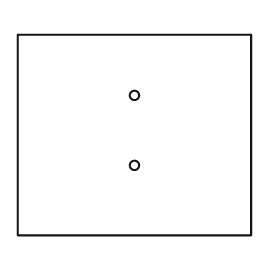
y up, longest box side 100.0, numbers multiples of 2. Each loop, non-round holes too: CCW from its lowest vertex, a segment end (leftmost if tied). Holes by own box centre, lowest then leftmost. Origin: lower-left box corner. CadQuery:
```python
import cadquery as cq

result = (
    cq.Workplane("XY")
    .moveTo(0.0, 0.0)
    .lineTo(100.0, 0.0)
    .lineTo(100.0, 86.0)
    .lineTo(0.0, 86.0)
    .close()
    .moveTo(50.0, 30.0)
    .circle(2.0)
    .moveTo(50.0, 60.0)
    .circle(2.0)
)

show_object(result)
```